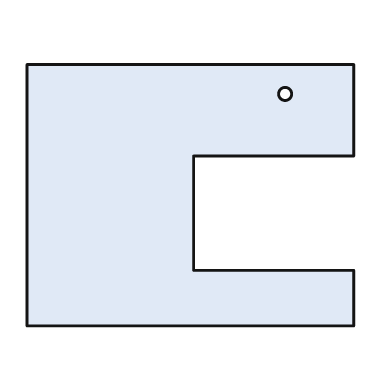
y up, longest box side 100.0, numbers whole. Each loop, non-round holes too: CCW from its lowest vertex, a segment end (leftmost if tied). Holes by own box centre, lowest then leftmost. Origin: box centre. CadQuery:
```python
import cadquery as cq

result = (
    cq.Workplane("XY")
    .moveTo(-50.0, -40.0)
    .lineTo(50.0, -40.0)
    .lineTo(50.0, -23.0)
    .lineTo(1.0, -23.0)
    .lineTo(1.0, 12.0)
    .lineTo(50.0, 12.0)
    .lineTo(50.0, 40.0)
    .lineTo(-50.0, 40.0)
    .close()
    .moveTo(29.0, 31.0)
    .circle(2.0)
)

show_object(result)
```